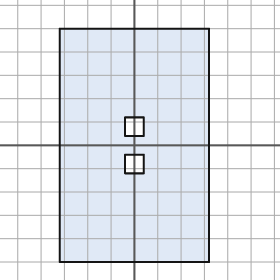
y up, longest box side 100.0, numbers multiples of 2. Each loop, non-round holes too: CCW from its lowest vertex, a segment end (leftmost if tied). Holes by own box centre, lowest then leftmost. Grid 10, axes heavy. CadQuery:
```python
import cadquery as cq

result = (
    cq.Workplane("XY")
    .moveTo(-32.0, -50.0)
    .lineTo(32.0, -50.0)
    .lineTo(32.0, 50.0)
    .lineTo(-32.0, 50.0)
    .close()
    .moveTo(-4.0, -12.0)
    .lineTo(4.0, -12.0)
    .lineTo(4.0, -4.0)
    .lineTo(-4.0, -4.0)
    .close()
    .moveTo(-4.0, 4.0)
    .lineTo(4.0, 4.0)
    .lineTo(4.0, 12.0)
    .lineTo(-4.0, 12.0)
    .close()
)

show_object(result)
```